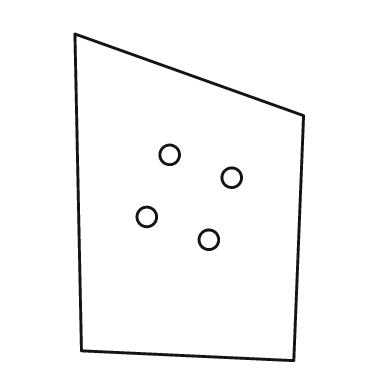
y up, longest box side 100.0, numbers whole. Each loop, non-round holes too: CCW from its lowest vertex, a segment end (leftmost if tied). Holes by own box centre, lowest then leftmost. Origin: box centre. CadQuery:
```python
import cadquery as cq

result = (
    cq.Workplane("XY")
    .moveTo(32.0, -50.0)
    .lineTo(35.0, 25.0)
    .lineTo(-35.0, 50.0)
    .lineTo(-33.0, -47.0)
    .close()
    .moveTo(6.0, -13.0)
    .circle(3.0)
    .moveTo(-13.0, -6.0)
    .circle(3.0)
    .moveTo(13.0, 6.0)
    .circle(3.0)
    .moveTo(-6.0, 13.0)
    .circle(3.0)
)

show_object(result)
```